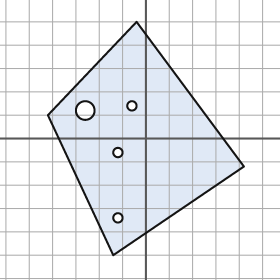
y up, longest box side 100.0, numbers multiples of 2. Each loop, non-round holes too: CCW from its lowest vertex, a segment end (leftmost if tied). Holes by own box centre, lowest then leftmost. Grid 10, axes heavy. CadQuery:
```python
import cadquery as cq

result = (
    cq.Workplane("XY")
    .moveTo(-14.0, -50.0)
    .lineTo(42.0, -12.0)
    .lineTo(-4.0, 50.0)
    .lineTo(-42.0, 10.0)
    .close()
    .moveTo(-12.0, -34.0)
    .circle(2.0)
    .moveTo(-12.0, -6.0)
    .circle(2.0)
    .moveTo(-26.0, 12.0)
    .circle(4.0)
    .moveTo(-6.0, 14.0)
    .circle(2.0)
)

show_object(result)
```